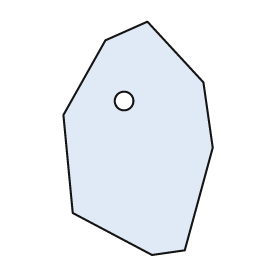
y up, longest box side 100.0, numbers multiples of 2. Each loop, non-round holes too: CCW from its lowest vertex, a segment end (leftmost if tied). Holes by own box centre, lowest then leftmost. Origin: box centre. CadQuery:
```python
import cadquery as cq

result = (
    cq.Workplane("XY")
    .moveTo(6.0, -50.0)
    .lineTo(20.0, -48.0)
    .lineTo(32.0, -4.0)
    .lineTo(28.0, 24.0)
    .lineTo(4.0, 50.0)
    .lineTo(-14.0, 42.0)
    .lineTo(-32.0, 10.0)
    .lineTo(-28.0, -32.0)
    .close()
    .moveTo(-6.0, 16.0)
    .circle(4.0)
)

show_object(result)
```